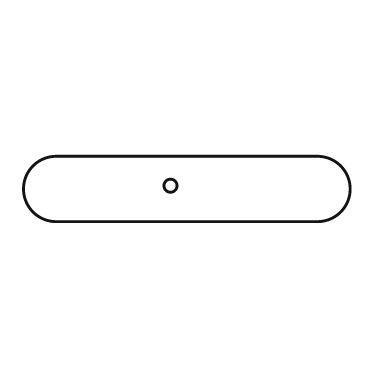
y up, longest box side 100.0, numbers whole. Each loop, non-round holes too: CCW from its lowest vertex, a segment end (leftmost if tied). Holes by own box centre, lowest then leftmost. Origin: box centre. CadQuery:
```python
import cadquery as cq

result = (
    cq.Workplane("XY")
    .moveTo(-40.0, -10.0)
    .lineTo(40.0, -10.0)
    .threePointArc((50.0, 0.0), (40.0, 10.0))
    .lineTo(-40.0, 10.0)
    .threePointArc((-50.0, 0.0), (-40.0, -10.0))
    .close()
    .moveTo(-5.0, 1.0)
    .circle(2.0)
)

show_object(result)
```